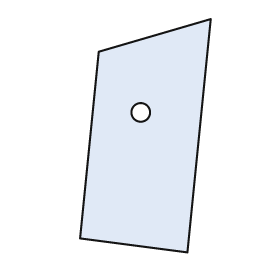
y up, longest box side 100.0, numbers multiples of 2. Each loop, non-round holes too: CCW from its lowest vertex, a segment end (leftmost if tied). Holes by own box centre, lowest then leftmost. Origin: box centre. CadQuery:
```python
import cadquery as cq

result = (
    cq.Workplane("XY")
    .moveTo(18.0, -50.0)
    .lineTo(28.0, 50.0)
    .lineTo(-20.0, 36.0)
    .lineTo(-28.0, -44.0)
    .close()
    .moveTo(-2.0, 10.0)
    .circle(4.0)
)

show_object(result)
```